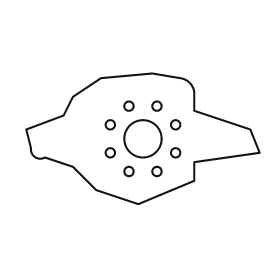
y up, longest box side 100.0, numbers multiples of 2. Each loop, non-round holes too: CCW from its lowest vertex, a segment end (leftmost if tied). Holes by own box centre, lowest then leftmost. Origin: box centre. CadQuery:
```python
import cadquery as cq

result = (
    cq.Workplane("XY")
    .moveTo(-2.0, -28.0)
    .lineTo(22.0, -18.0)
    .lineTo(22.0, -10.0)
    .lineTo(50.0, -6.0)
    .lineTo(46.0, 4.0)
    .lineTo(22.0, 12.0)
    .lineTo(22.0, 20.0)
    .threePointArc((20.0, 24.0), (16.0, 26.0))
    .lineTo(4.0, 28.0)
    .lineTo(-18.0, 26.0)
    .lineTo(-30.0, 18.0)
    .lineTo(-34.0, 10.0)
    .lineTo(-50.0, 4.0)
    .lineTo(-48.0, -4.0)
    .threePointArc((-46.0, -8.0), (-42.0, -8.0))
    .lineTo(-30.0, -12.0)
    .lineTo(-20.0, -22.0)
    .close()
    .moveTo(-6.0, -14.0)
    .circle(2.0)
    .moveTo(6.0, -14.0)
    .circle(2.0)
    .moveTo(-14.0, -6.0)
    .circle(2.0)
    .moveTo(14.0, -6.0)
    .circle(2.0)
    .moveTo(0.0, 0.0)
    .circle(8.0)
    .moveTo(-14.0, 6.0)
    .circle(2.0)
    .moveTo(14.0, 6.0)
    .circle(2.0)
    .moveTo(-6.0, 14.0)
    .circle(2.0)
    .moveTo(6.0, 14.0)
    .circle(2.0)
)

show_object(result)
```